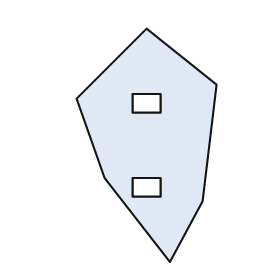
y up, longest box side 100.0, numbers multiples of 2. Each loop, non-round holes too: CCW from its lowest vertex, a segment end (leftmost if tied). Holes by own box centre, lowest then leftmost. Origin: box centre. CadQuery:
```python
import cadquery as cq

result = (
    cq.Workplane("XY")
    .moveTo(10.0, -50.0)
    .lineTo(24.0, -24.0)
    .lineTo(30.0, 26.0)
    .lineTo(0.0, 50.0)
    .lineTo(-30.0, 20.0)
    .lineTo(-18.0, -14.0)
    .close()
    .moveTo(-6.0, -22.0)
    .lineTo(6.0, -22.0)
    .lineTo(6.0, -14.0)
    .lineTo(-6.0, -14.0)
    .close()
    .moveTo(-6.0, 14.0)
    .lineTo(6.0, 14.0)
    .lineTo(6.0, 22.0)
    .lineTo(-6.0, 22.0)
    .close()
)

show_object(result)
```